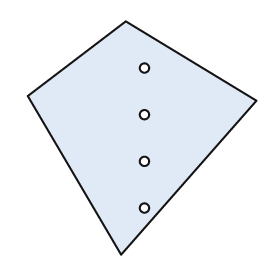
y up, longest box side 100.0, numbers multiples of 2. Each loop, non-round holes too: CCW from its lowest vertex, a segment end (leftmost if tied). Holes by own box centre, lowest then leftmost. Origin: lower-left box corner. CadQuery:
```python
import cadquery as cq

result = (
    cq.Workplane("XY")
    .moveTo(40.0, 0.0)
    .lineTo(98.0, 66.0)
    .lineTo(42.0, 100.0)
    .lineTo(0.0, 68.0)
    .close()
    .moveTo(50.0, 20.0)
    .circle(2.0)
    .moveTo(50.0, 40.0)
    .circle(2.0)
    .moveTo(50.0, 60.0)
    .circle(2.0)
    .moveTo(50.0, 80.0)
    .circle(2.0)
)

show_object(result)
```